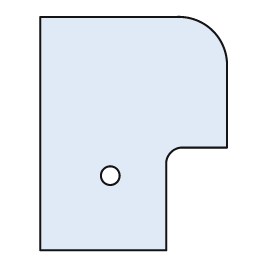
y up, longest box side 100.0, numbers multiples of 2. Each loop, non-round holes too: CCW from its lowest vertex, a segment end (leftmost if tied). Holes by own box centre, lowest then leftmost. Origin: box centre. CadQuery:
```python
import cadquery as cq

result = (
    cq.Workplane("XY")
    .moveTo(-40.0, -50.0)
    .lineTo(14.0, -50.0)
    .lineTo(14.0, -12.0)
    .threePointArc((16.0, -8.0), (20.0, -6.0))
    .lineTo(40.0, -6.0)
    .lineTo(40.0, 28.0)
    .threePointArc((34.0, 44.0), (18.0, 50.0))
    .lineTo(-40.0, 50.0)
    .close()
    .moveTo(-10.0, -18.0)
    .circle(4.0)
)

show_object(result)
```